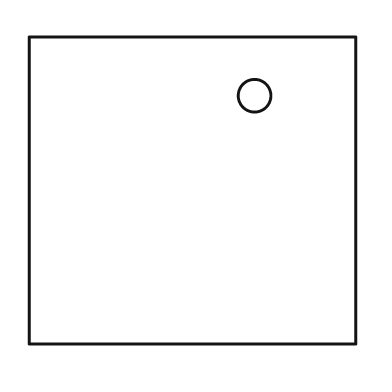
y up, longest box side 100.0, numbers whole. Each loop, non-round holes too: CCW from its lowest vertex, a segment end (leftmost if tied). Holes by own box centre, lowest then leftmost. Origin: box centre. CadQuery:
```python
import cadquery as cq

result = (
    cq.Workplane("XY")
    .moveTo(-50.0, -47.0)
    .lineTo(50.0, -47.0)
    .lineTo(50.0, 47.0)
    .lineTo(-50.0, 47.0)
    .close()
    .moveTo(19.0, 29.0)
    .circle(5.0)
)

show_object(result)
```